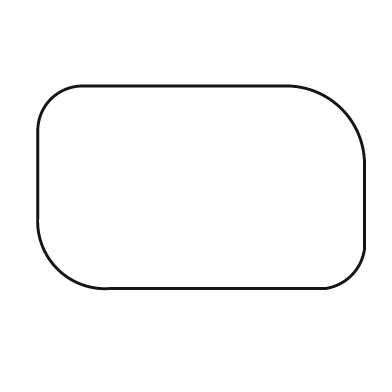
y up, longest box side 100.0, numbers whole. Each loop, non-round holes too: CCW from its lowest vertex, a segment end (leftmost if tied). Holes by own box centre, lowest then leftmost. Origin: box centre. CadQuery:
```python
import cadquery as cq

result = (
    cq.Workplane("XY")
    .moveTo(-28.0, -31.0)
    .lineTo(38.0, -31.0)
    .threePointArc((46.0, -27.0), (50.0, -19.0))
    .lineTo(50.0, 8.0)
    .threePointArc((43.0, 24.0), (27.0, 31.0))
    .lineTo(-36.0, 31.0)
    .threePointArc((-46.0, 27.0), (-50.0, 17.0))
    .lineTo(-50.0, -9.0)
    .threePointArc((-44.0, -25.0), (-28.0, -31.0))
    .close()
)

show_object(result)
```